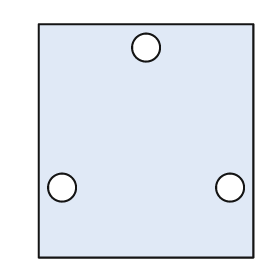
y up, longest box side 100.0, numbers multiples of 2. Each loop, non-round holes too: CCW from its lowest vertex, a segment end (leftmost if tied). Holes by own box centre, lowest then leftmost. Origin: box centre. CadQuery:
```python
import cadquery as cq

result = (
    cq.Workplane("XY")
    .moveTo(-46.0, -50.0)
    .lineTo(46.0, -50.0)
    .lineTo(46.0, 50.0)
    .lineTo(-46.0, 50.0)
    .close()
    .moveTo(-36.0, -20.0)
    .circle(6.0)
    .moveTo(36.0, -20.0)
    .circle(6.0)
    .moveTo(0.0, 40.0)
    .circle(6.0)
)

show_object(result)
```